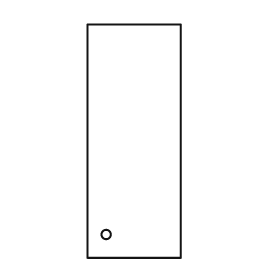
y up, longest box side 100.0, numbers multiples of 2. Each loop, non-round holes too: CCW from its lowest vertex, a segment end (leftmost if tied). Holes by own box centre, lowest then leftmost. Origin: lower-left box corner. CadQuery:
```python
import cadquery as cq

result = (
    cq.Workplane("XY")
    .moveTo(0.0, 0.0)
    .lineTo(40.0, 0.0)
    .lineTo(40.0, 100.0)
    .lineTo(0.0, 100.0)
    .close()
    .moveTo(8.0, 10.0)
    .circle(2.0)
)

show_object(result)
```